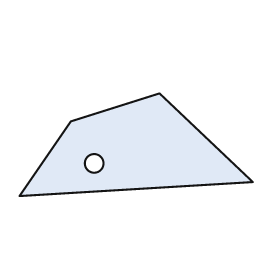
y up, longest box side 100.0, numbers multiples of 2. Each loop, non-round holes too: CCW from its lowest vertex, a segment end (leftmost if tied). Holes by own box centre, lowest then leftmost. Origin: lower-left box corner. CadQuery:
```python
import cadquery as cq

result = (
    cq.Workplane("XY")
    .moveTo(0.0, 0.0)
    .lineTo(100.0, 6.0)
    .lineTo(60.0, 44.0)
    .lineTo(22.0, 32.0)
    .close()
    .moveTo(32.0, 14.0)
    .circle(4.0)
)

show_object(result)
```